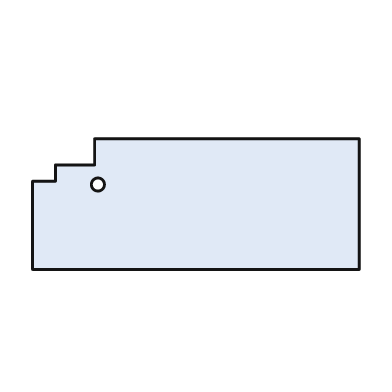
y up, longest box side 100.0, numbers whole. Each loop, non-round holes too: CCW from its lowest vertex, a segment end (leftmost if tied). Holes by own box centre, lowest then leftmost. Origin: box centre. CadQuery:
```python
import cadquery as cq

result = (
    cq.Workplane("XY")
    .moveTo(-50.0, -20.0)
    .lineTo(50.0, -20.0)
    .lineTo(50.0, 20.0)
    .lineTo(-31.0, 20.0)
    .lineTo(-31.0, 12.0)
    .lineTo(-43.0, 12.0)
    .lineTo(-43.0, 7.0)
    .lineTo(-50.0, 7.0)
    .close()
    .moveTo(-30.0, 6.0)
    .circle(2.0)
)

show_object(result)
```